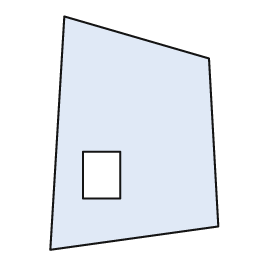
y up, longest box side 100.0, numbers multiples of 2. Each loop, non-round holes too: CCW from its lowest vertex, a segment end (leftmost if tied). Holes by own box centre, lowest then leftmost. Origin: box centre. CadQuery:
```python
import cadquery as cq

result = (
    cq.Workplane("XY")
    .moveTo(-36.0, -50.0)
    .lineTo(36.0, -40.0)
    .lineTo(32.0, 32.0)
    .lineTo(-30.0, 50.0)
    .close()
    .moveTo(-22.0, -28.0)
    .lineTo(-6.0, -28.0)
    .lineTo(-6.0, -8.0)
    .lineTo(-22.0, -8.0)
    .close()
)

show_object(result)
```